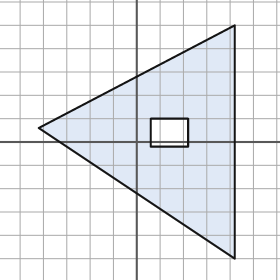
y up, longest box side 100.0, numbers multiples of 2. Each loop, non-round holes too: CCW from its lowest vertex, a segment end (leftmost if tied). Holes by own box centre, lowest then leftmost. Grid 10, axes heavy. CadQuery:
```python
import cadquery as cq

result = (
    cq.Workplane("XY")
    .moveTo(42.0, -50.0)
    .lineTo(42.0, 50.0)
    .lineTo(-42.0, 6.0)
    .close()
    .moveTo(6.0, -2.0)
    .lineTo(22.0, -2.0)
    .lineTo(22.0, 10.0)
    .lineTo(6.0, 10.0)
    .close()
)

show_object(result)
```